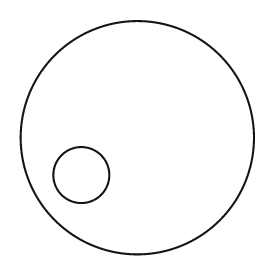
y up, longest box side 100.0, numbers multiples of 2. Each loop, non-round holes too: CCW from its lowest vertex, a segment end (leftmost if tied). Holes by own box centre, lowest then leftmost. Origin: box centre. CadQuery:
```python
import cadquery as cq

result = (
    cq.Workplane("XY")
    .moveTo(0.0, 0.0)
    .circle(50.0)
    .moveTo(-24.0, -16.0)
    .circle(12.0)
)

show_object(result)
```